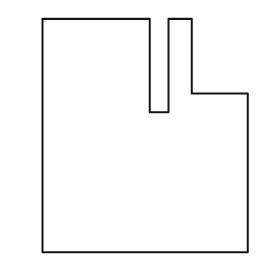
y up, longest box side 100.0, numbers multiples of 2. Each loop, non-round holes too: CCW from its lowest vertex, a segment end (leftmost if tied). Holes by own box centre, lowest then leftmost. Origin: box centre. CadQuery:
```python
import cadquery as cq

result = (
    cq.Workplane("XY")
    .moveTo(-44.0, -50.0)
    .lineTo(44.0, -50.0)
    .lineTo(44.0, 18.0)
    .lineTo(20.0, 18.0)
    .lineTo(20.0, 50.0)
    .lineTo(10.0, 50.0)
    .lineTo(10.0, 10.0)
    .lineTo(2.0, 10.0)
    .lineTo(2.0, 50.0)
    .lineTo(-44.0, 50.0)
    .close()
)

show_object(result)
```